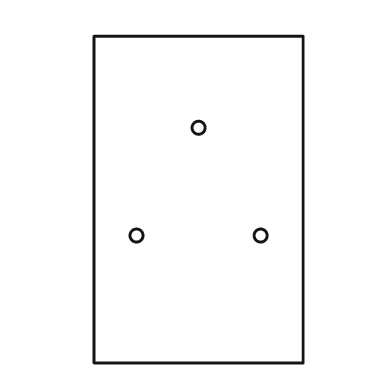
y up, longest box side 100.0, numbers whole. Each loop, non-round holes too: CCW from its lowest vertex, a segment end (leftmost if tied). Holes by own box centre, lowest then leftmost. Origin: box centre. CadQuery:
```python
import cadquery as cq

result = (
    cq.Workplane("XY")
    .moveTo(-32.0, -50.0)
    .lineTo(32.0, -50.0)
    .lineTo(32.0, 50.0)
    .lineTo(-32.0, 50.0)
    .close()
    .moveTo(-19.0, -11.0)
    .circle(2.0)
    .moveTo(19.0, -11.0)
    .circle(2.0)
    .moveTo(0.0, 22.0)
    .circle(2.0)
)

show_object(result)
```